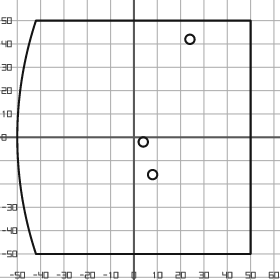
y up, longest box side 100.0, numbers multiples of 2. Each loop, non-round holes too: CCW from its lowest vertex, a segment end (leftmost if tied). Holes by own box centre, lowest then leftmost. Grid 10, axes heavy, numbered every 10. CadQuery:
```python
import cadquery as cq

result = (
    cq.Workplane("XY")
    .moveTo(-42.0, -50.0)
    .lineTo(50.0, -50.0)
    .lineTo(50.0, 50.0)
    .lineTo(-42.0, 50.0)
    .threePointArc((-50.0, 0.0), (-42.0, -50.0))
    .close()
    .moveTo(8.0, -16.0)
    .circle(2.0)
    .moveTo(4.0, -2.0)
    .circle(2.0)
    .moveTo(24.0, 42.0)
    .circle(2.0)
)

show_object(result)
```